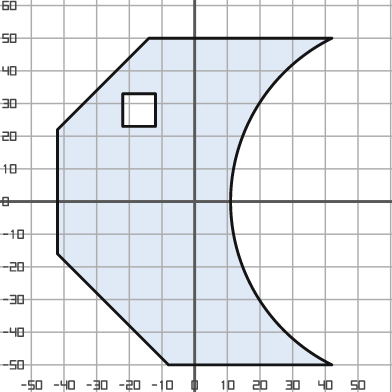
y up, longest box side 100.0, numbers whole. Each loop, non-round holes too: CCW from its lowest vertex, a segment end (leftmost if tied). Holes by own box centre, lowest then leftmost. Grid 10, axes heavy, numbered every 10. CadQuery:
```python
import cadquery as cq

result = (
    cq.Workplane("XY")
    .moveTo(-8.0, -50.0)
    .lineTo(42.0, -50.0)
    .threePointArc((11.0, 0.0), (42.0, 50.0))
    .lineTo(-14.0, 50.0)
    .lineTo(-42.0, 22.0)
    .lineTo(-42.0, -16.0)
    .close()
    .moveTo(-22.0, 23.0)
    .lineTo(-12.0, 23.0)
    .lineTo(-12.0, 33.0)
    .lineTo(-22.0, 33.0)
    .close()
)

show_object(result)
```